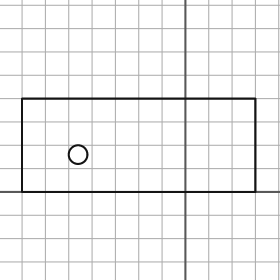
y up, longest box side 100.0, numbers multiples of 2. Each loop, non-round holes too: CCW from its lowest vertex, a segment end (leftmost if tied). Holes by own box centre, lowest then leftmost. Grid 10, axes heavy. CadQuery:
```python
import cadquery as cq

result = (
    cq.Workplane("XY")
    .moveTo(-70.0, 0.0)
    .lineTo(30.0, 0.0)
    .lineTo(30.0, 40.0)
    .lineTo(-70.0, 40.0)
    .close()
    .moveTo(-46.0, 16.0)
    .circle(4.0)
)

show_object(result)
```